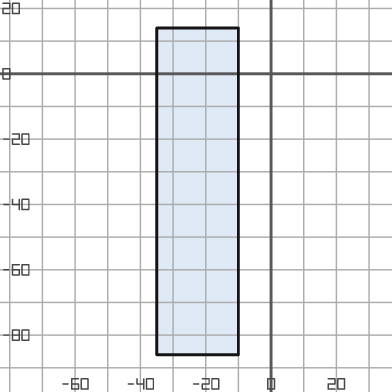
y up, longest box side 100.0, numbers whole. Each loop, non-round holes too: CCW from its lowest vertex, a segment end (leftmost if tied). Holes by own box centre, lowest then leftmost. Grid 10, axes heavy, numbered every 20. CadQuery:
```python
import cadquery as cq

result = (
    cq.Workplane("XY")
    .moveTo(-35.0, -86.0)
    .lineTo(-10.0, -86.0)
    .lineTo(-10.0, 14.0)
    .lineTo(-35.0, 14.0)
    .close()
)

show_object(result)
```